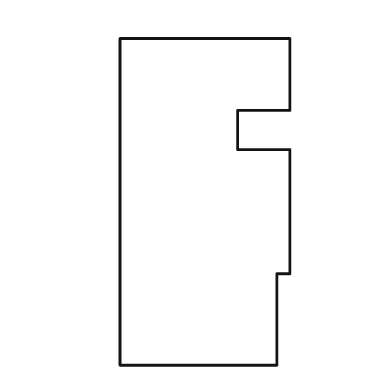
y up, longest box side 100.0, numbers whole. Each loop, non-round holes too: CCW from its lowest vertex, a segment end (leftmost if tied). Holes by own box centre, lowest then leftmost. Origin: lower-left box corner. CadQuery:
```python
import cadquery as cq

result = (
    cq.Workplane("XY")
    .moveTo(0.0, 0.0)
    .lineTo(48.0, 0.0)
    .lineTo(48.0, 28.0)
    .lineTo(52.0, 28.0)
    .lineTo(52.0, 66.0)
    .lineTo(36.0, 66.0)
    .lineTo(36.0, 78.0)
    .lineTo(52.0, 78.0)
    .lineTo(52.0, 100.0)
    .lineTo(0.0, 100.0)
    .close()
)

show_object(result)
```